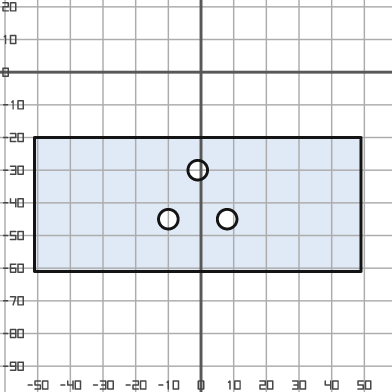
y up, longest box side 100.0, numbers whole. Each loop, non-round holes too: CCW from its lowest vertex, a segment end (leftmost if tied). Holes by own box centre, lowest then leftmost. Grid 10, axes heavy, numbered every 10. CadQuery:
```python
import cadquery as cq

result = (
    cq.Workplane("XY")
    .moveTo(-51.0, -61.0)
    .lineTo(49.0, -61.0)
    .lineTo(49.0, -20.0)
    .lineTo(-51.0, -20.0)
    .close()
    .moveTo(-10.0, -45.0)
    .circle(3.0)
    .moveTo(8.0, -45.0)
    .circle(3.0)
    .moveTo(-1.0, -30.0)
    .circle(3.0)
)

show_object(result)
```